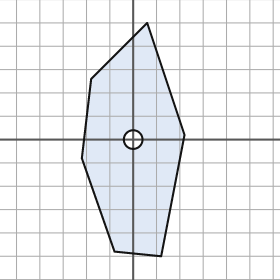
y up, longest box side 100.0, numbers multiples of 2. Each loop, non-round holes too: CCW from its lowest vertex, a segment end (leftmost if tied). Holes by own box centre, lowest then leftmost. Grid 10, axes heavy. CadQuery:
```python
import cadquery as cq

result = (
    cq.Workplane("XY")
    .moveTo(12.0, -50.0)
    .lineTo(22.0, 2.0)
    .lineTo(6.0, 50.0)
    .lineTo(-18.0, 26.0)
    .lineTo(-22.0, -8.0)
    .lineTo(-8.0, -48.0)
    .close()
    .moveTo(0.0, 0.0)
    .circle(4.0)
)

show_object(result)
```